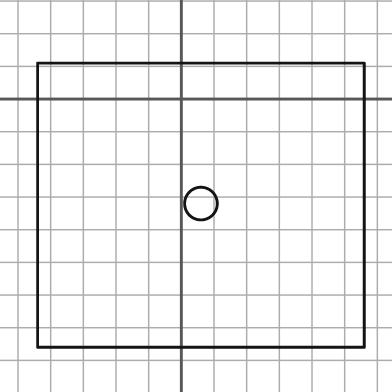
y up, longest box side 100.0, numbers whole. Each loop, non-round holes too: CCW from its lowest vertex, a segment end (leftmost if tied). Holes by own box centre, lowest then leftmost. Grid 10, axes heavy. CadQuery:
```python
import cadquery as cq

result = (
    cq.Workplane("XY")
    .moveTo(-44.0, -76.0)
    .lineTo(56.0, -76.0)
    .lineTo(56.0, 11.0)
    .lineTo(-44.0, 11.0)
    .close()
    .moveTo(6.0, -32.0)
    .circle(5.0)
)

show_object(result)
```